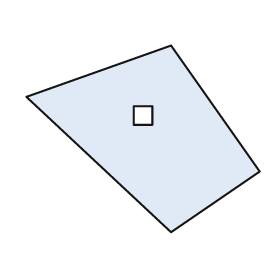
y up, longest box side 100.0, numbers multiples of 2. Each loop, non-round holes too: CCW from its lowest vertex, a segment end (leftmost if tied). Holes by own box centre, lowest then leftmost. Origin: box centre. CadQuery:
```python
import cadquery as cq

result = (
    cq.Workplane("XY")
    .moveTo(12.0, -40.0)
    .lineTo(50.0, -14.0)
    .lineTo(12.0, 40.0)
    .lineTo(-50.0, 18.0)
    .close()
    .moveTo(-4.0, 6.0)
    .lineTo(4.0, 6.0)
    .lineTo(4.0, 14.0)
    .lineTo(-4.0, 14.0)
    .close()
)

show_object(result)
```